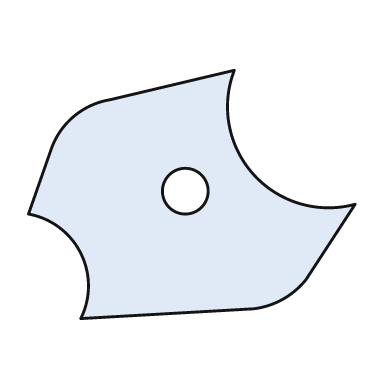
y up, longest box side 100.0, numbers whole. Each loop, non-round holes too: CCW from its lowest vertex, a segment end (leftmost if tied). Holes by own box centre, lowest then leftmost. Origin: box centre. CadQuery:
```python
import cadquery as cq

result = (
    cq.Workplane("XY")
    .moveTo(-34.0, -38.0)
    .lineTo(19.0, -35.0)
    .threePointArc((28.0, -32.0), (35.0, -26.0))
    .lineTo(50.0, -3.0)
    .threePointArc((19.0, 6.0), (13.0, 38.0))
    .lineTo(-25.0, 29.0)
    .threePointArc((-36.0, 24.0), (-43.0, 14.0))
    .lineTo(-50.0, -6.0)
    .threePointArc((-34.0, -18.0), (-34.0, -38.0))
    .close()
    .moveTo(-2.0, 1.0)
    .circle(7.0)
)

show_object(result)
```